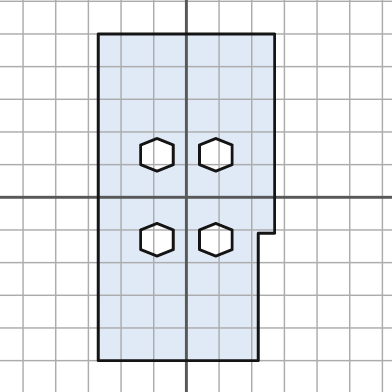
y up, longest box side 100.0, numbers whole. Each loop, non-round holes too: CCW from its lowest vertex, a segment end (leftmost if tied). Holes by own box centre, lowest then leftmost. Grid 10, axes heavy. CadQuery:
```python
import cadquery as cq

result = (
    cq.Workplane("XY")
    .moveTo(-27.0, -50.0)
    .lineTo(22.0, -50.0)
    .lineTo(22.0, -11.0)
    .lineTo(27.0, -11.0)
    .lineTo(27.0, 50.0)
    .lineTo(-27.0, 50.0)
    .close()
    .moveTo(-9.0, -18.0)
    .lineTo(-4.0, -16.0)
    .lineTo(-4.0, -10.0)
    .lineTo(-9.0, -8.0)
    .lineTo(-14.0, -10.0)
    .lineTo(-14.0, -16.0)
    .close()
    .moveTo(9.0, -18.0)
    .lineTo(14.0, -16.0)
    .lineTo(14.0, -10.0)
    .lineTo(9.0, -8.0)
    .lineTo(4.0, -10.0)
    .lineTo(4.0, -16.0)
    .close()
    .moveTo(-9.0, 8.0)
    .lineTo(-4.0, 10.0)
    .lineTo(-4.0, 16.0)
    .lineTo(-9.0, 18.0)
    .lineTo(-14.0, 16.0)
    .lineTo(-14.0, 10.0)
    .close()
    .moveTo(9.0, 8.0)
    .lineTo(14.0, 10.0)
    .lineTo(14.0, 16.0)
    .lineTo(9.0, 18.0)
    .lineTo(4.0, 16.0)
    .lineTo(4.0, 10.0)
    .close()
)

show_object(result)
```